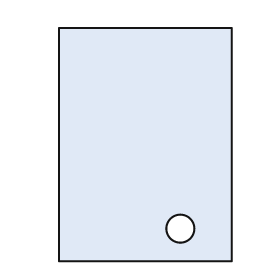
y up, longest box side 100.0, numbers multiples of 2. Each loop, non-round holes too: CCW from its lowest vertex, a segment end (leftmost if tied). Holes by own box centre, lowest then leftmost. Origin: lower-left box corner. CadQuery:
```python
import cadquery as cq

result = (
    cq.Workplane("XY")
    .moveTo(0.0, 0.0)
    .lineTo(74.0, 0.0)
    .lineTo(74.0, 100.0)
    .lineTo(0.0, 100.0)
    .close()
    .moveTo(52.0, 14.0)
    .circle(6.0)
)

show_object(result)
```